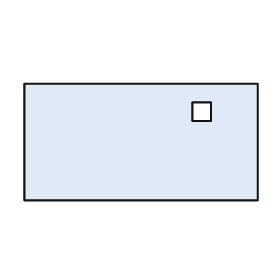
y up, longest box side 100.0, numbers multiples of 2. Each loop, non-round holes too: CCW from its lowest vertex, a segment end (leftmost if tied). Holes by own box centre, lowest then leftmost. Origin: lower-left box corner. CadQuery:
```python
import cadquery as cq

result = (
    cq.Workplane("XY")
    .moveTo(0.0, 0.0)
    .lineTo(100.0, 0.0)
    .lineTo(100.0, 50.0)
    .lineTo(0.0, 50.0)
    .close()
    .moveTo(72.0, 34.0)
    .lineTo(80.0, 34.0)
    .lineTo(80.0, 42.0)
    .lineTo(72.0, 42.0)
    .close()
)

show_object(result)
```